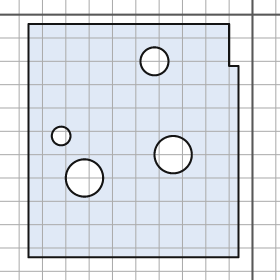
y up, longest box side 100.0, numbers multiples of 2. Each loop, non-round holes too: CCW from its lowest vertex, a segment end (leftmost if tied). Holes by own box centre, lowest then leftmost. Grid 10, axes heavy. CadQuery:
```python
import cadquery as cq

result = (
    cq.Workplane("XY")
    .moveTo(-96.0, -104.0)
    .lineTo(-6.0, -104.0)
    .lineTo(-6.0, -22.0)
    .lineTo(-10.0, -22.0)
    .lineTo(-10.0, -4.0)
    .lineTo(-96.0, -4.0)
    .close()
    .moveTo(-72.0, -70.0)
    .circle(8.0)
    .moveTo(-34.0, -60.0)
    .circle(8.0)
    .moveTo(-82.0, -52.0)
    .circle(4.0)
    .moveTo(-42.0, -20.0)
    .circle(6.0)
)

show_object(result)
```